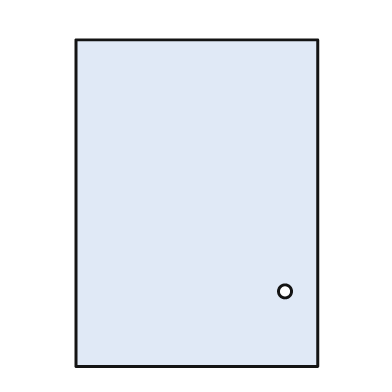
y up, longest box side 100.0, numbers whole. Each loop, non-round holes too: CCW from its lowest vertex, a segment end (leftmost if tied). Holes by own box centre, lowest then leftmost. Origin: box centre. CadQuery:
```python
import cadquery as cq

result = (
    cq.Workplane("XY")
    .moveTo(-37.0, -50.0)
    .lineTo(37.0, -50.0)
    .lineTo(37.0, 50.0)
    .lineTo(-37.0, 50.0)
    .close()
    .moveTo(27.0, -27.0)
    .circle(2.0)
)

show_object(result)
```